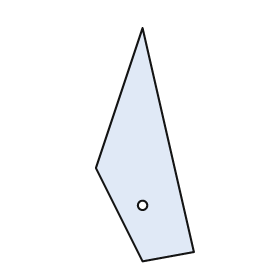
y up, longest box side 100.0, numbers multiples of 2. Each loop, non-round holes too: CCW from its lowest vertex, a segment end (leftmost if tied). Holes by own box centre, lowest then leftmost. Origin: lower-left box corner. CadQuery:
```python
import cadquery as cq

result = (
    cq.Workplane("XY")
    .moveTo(20.0, 0.0)
    .lineTo(42.0, 4.0)
    .lineTo(20.0, 100.0)
    .lineTo(0.0, 40.0)
    .close()
    .moveTo(20.0, 24.0)
    .circle(2.0)
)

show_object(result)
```